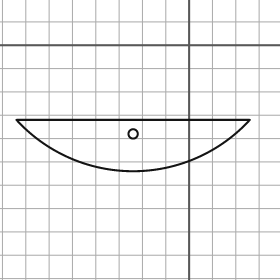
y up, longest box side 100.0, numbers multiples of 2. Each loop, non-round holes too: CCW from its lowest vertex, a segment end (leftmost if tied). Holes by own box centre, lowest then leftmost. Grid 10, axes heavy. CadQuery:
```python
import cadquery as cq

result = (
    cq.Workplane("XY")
    .moveTo(-74.0, -32.0)
    .threePointArc((-24.0, -54.0), (26.0, -32.0))
    .close()
    .moveTo(-24.0, -38.0)
    .circle(2.0)
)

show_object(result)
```